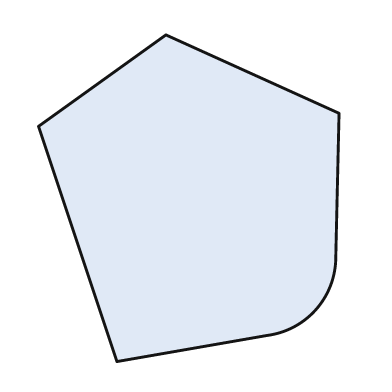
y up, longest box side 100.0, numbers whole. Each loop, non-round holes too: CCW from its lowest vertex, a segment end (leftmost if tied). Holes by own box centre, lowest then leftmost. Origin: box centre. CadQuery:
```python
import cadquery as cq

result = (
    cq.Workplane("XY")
    .moveTo(-22.0, -50.0)
    .lineTo(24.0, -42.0)
    .threePointArc((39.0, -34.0), (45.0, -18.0))
    .lineTo(46.0, 26.0)
    .lineTo(-7.0, 50.0)
    .lineTo(-46.0, 22.0)
    .close()
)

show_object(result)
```